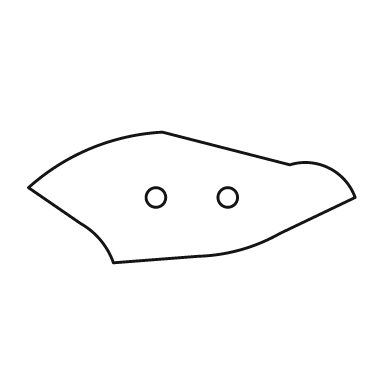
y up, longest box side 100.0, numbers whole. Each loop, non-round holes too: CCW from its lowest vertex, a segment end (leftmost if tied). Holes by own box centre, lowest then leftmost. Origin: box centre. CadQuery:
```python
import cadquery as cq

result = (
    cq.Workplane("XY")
    .moveTo(-24.0, -20.0)
    .lineTo(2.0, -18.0)
    .threePointArc((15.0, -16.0), (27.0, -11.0))
    .lineTo(50.0, 0.0)
    .threePointArc((42.0, 9.0), (30.0, 10.0))
    .lineTo(-9.0, 20.0)
    .threePointArc((-31.0, 15.0), (-50.0, 3.0))
    .lineTo(-34.0, -8.0)
    .threePointArc((-28.0, -13.0), (-24.0, -20.0))
    .close()
    .moveTo(-11.0, 0.0)
    .circle(3.0)
    .moveTo(11.0, 0.0)
    .circle(3.0)
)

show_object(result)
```